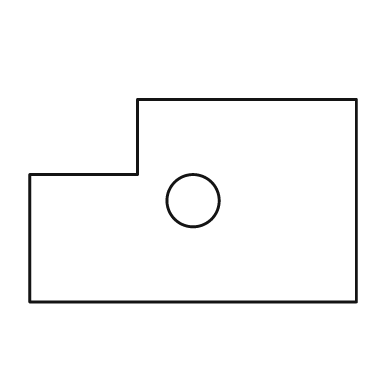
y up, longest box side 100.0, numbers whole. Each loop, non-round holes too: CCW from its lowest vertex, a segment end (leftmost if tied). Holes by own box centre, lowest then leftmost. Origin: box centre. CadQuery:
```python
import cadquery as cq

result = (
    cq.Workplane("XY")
    .moveTo(-50.0, -31.0)
    .lineTo(50.0, -31.0)
    .lineTo(50.0, 31.0)
    .lineTo(-17.0, 31.0)
    .lineTo(-17.0, 8.0)
    .lineTo(-50.0, 8.0)
    .close()
    .moveTo(0.0, 0.0)
    .circle(8.0)
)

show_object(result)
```